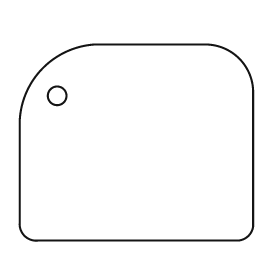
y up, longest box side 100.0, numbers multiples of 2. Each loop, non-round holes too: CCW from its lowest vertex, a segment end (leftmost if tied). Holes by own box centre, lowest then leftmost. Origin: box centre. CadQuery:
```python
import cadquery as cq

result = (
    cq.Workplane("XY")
    .moveTo(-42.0, -42.0)
    .lineTo(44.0, -42.0)
    .threePointArc((48.0, -40.0), (50.0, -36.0))
    .lineTo(50.0, 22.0)
    .threePointArc((44.0, 36.0), (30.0, 42.0))
    .lineTo(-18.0, 42.0)
    .threePointArc((-40.0, 32.0), (-50.0, 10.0))
    .lineTo(-50.0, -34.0)
    .threePointArc((-48.0, -40.0), (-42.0, -42.0))
    .close()
    .moveTo(-34.0, 20.0)
    .circle(4.0)
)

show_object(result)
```